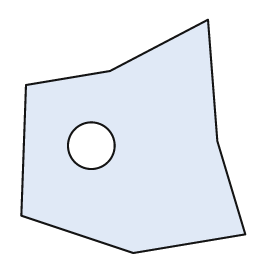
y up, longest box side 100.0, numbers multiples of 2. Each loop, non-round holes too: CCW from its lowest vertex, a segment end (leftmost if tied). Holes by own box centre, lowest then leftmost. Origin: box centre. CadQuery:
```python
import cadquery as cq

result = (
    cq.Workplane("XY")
    .moveTo(0.0, -50.0)
    .lineTo(48.0, -42.0)
    .lineTo(36.0, -2.0)
    .lineTo(32.0, 50.0)
    .lineTo(-10.0, 28.0)
    .lineTo(-46.0, 22.0)
    .lineTo(-48.0, -34.0)
    .close()
    .moveTo(-18.0, -4.0)
    .circle(10.0)
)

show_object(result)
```